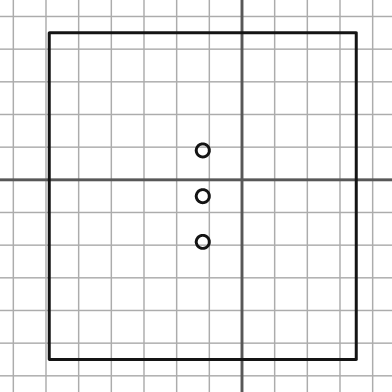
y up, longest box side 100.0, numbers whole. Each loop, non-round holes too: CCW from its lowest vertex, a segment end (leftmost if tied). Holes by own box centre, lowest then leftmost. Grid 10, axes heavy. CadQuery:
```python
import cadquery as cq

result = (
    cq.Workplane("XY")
    .moveTo(-59.0, -55.0)
    .lineTo(35.0, -55.0)
    .lineTo(35.0, 45.0)
    .lineTo(-59.0, 45.0)
    .close()
    .moveTo(-12.0, -19.0)
    .circle(2.0)
    .moveTo(-12.0, -5.0)
    .circle(2.0)
    .moveTo(-12.0, 9.0)
    .circle(2.0)
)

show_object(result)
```